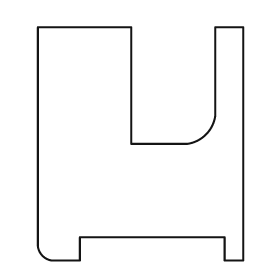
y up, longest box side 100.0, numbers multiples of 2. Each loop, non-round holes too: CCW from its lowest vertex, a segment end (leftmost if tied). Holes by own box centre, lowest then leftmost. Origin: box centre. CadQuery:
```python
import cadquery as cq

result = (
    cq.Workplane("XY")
    .moveTo(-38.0, -50.0)
    .lineTo(-26.0, -50.0)
    .lineTo(-26.0, -40.0)
    .lineTo(36.0, -40.0)
    .lineTo(36.0, -50.0)
    .lineTo(44.0, -50.0)
    .lineTo(44.0, 50.0)
    .lineTo(32.0, 50.0)
    .lineTo(32.0, 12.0)
    .threePointArc((28.0, 4.0), (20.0, 0.0))
    .lineTo(-4.0, 0.0)
    .lineTo(-4.0, 50.0)
    .lineTo(-44.0, 50.0)
    .lineTo(-44.0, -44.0)
    .threePointArc((-42.0, -48.0), (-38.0, -50.0))
    .close()
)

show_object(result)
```